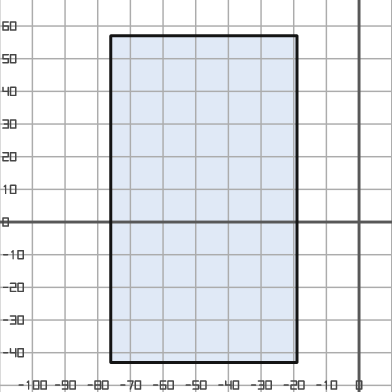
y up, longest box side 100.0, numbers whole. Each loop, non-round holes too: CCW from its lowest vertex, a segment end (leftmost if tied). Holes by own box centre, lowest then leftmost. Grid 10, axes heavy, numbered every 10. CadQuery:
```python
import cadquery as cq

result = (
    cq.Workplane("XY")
    .moveTo(-76.0, -43.0)
    .lineTo(-19.0, -43.0)
    .lineTo(-19.0, 57.0)
    .lineTo(-76.0, 57.0)
    .close()
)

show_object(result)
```